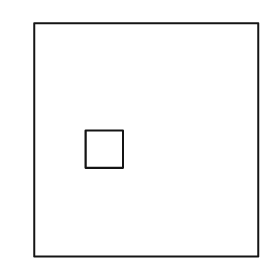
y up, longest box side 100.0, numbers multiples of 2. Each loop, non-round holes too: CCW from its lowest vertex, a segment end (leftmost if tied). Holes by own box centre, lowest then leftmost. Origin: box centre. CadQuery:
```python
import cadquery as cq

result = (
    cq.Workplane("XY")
    .moveTo(-48.0, -50.0)
    .lineTo(48.0, -50.0)
    .lineTo(48.0, 50.0)
    .lineTo(-48.0, 50.0)
    .close()
    .moveTo(-26.0, -12.0)
    .lineTo(-10.0, -12.0)
    .lineTo(-10.0, 4.0)
    .lineTo(-26.0, 4.0)
    .close()
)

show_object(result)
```